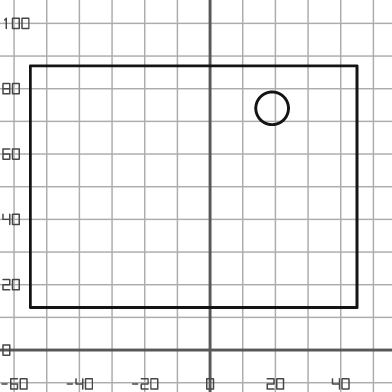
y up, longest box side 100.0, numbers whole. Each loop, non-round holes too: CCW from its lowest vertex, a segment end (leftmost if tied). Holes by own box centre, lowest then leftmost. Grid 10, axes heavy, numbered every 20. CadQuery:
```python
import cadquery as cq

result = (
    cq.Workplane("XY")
    .moveTo(-55.0, 13.0)
    .lineTo(45.0, 13.0)
    .lineTo(45.0, 87.0)
    .lineTo(-55.0, 87.0)
    .close()
    .moveTo(19.0, 74.0)
    .circle(5.0)
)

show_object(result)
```